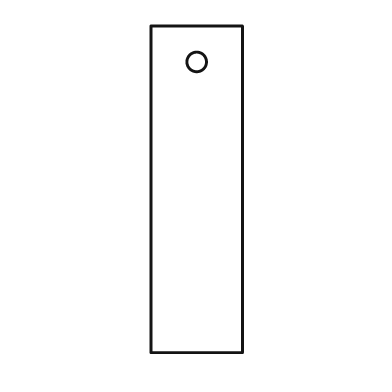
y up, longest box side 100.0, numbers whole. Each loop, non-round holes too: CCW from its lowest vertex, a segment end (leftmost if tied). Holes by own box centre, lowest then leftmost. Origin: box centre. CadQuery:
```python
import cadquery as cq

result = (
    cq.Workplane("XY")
    .moveTo(-14.0, -50.0)
    .lineTo(14.0, -50.0)
    .lineTo(14.0, 50.0)
    .lineTo(-14.0, 50.0)
    .close()
    .moveTo(0.0, 39.0)
    .circle(3.0)
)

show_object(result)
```